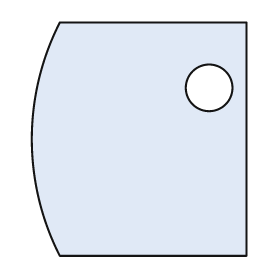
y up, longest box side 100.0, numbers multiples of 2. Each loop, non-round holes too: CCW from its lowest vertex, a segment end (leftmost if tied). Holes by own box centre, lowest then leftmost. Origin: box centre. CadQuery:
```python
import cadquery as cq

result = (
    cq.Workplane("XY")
    .moveTo(-34.0, -50.0)
    .lineTo(46.0, -50.0)
    .lineTo(46.0, 50.0)
    .lineTo(-34.0, 50.0)
    .threePointArc((-46.0, 0.0), (-34.0, -50.0))
    .close()
    .moveTo(30.0, 22.0)
    .circle(10.0)
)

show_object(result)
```